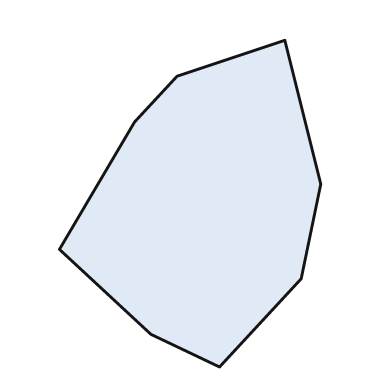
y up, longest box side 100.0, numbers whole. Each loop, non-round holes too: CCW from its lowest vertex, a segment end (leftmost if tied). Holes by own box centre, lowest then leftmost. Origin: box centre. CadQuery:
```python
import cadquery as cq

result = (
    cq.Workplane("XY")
    .moveTo(9.0, -50.0)
    .lineTo(34.0, -23.0)
    .lineTo(40.0, 6.0)
    .lineTo(29.0, 50.0)
    .lineTo(-4.0, 39.0)
    .lineTo(-17.0, 25.0)
    .lineTo(-40.0, -14.0)
    .lineTo(-12.0, -40.0)
    .close()
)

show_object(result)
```